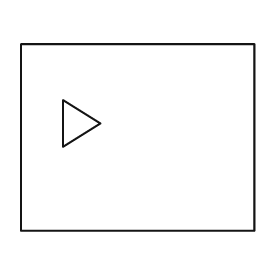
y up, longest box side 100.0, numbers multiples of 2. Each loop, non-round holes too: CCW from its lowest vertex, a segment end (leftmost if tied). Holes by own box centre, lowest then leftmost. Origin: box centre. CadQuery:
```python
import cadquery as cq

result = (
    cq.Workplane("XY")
    .moveTo(-50.0, -40.0)
    .lineTo(50.0, -40.0)
    .lineTo(50.0, 40.0)
    .lineTo(-50.0, 40.0)
    .close()
    .moveTo(-32.0, -4.0)
    .lineTo(-16.0, 6.0)
    .lineTo(-32.0, 16.0)
    .close()
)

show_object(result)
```